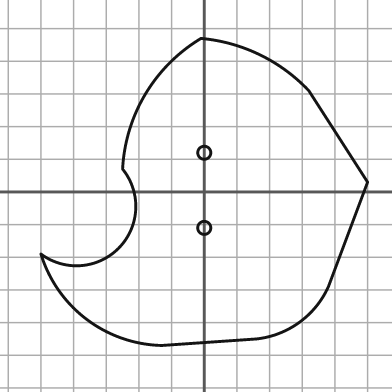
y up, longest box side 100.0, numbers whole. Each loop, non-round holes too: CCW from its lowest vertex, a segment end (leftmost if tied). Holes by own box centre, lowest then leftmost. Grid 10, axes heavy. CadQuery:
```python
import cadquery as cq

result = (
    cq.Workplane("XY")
    .moveTo(-13.0, -47.0)
    .lineTo(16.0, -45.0)
    .threePointArc((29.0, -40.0), (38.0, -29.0))
    .lineTo(50.0, 3.0)
    .lineTo(32.0, 31.0)
    .threePointArc((17.0, 42.0), (-1.0, 47.0))
    .threePointArc((-18.0, 30.0), (-25.0, 7.0))
    .threePointArc((-26.0, -17.0), (-50.0, -19.0))
    .threePointArc((-36.0, -39.0), (-13.0, -47.0))
    .close()
    .moveTo(0.0, -11.0)
    .circle(2.0)
    .moveTo(0.0, 12.0)
    .circle(2.0)
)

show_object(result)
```